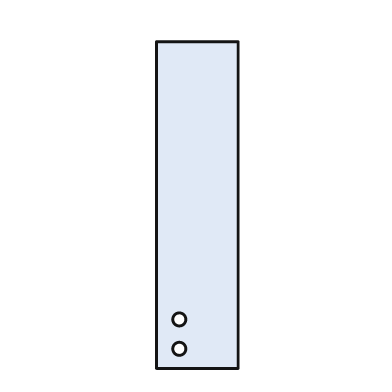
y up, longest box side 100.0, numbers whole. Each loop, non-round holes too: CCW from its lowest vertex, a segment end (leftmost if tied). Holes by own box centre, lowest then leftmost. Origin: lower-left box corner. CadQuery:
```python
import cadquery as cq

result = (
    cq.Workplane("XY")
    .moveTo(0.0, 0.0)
    .lineTo(25.0, 0.0)
    .lineTo(25.0, 100.0)
    .lineTo(0.0, 100.0)
    .close()
    .moveTo(7.0, 6.0)
    .circle(2.0)
    .moveTo(7.0, 15.0)
    .circle(2.0)
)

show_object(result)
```